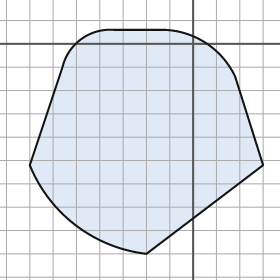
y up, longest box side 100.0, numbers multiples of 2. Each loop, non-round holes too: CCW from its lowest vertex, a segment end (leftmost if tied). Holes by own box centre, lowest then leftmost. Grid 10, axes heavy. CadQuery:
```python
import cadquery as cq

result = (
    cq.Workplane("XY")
    .moveTo(-20.0, -90.0)
    .lineTo(30.0, -52.0)
    .lineTo(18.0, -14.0)
    .threePointArc((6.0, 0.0), (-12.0, 6.0))
    .lineTo(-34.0, 6.0)
    .threePointArc((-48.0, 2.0), (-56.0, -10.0))
    .lineTo(-70.0, -52.0)
    .threePointArc((-50.0, -78.0), (-20.0, -90.0))
    .close()
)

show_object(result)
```